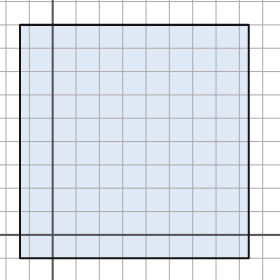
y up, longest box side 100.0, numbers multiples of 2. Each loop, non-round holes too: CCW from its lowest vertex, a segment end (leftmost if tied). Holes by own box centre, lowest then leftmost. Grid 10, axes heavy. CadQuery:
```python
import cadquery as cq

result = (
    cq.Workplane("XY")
    .moveTo(-14.0, -10.0)
    .lineTo(84.0, -10.0)
    .lineTo(84.0, 90.0)
    .lineTo(-14.0, 90.0)
    .close()
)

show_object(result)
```